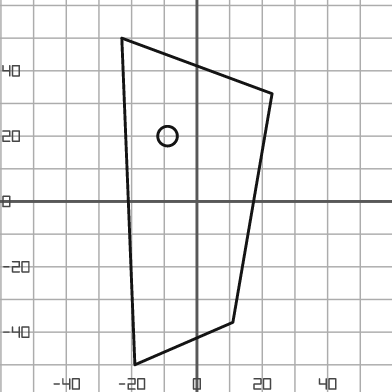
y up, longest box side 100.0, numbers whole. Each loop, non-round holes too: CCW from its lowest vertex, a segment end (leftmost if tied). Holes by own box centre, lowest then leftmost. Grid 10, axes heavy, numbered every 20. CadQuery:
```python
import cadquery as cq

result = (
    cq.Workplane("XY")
    .moveTo(-19.0, -50.0)
    .lineTo(11.0, -37.0)
    .lineTo(23.0, 33.0)
    .lineTo(-23.0, 50.0)
    .close()
    .moveTo(-9.0, 20.0)
    .circle(3.0)
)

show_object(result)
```